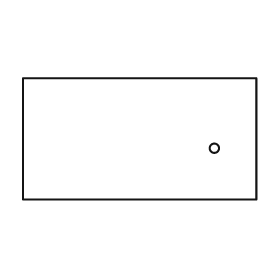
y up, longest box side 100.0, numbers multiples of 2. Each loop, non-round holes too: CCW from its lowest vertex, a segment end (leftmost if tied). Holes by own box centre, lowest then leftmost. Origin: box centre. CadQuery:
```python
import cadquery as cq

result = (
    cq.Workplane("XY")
    .moveTo(-50.0, -26.0)
    .lineTo(50.0, -26.0)
    .lineTo(50.0, 26.0)
    .lineTo(-50.0, 26.0)
    .close()
    .moveTo(32.0, -4.0)
    .circle(2.0)
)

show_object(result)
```